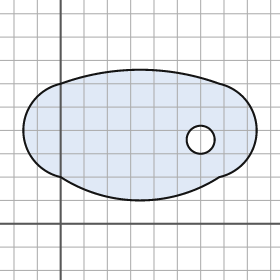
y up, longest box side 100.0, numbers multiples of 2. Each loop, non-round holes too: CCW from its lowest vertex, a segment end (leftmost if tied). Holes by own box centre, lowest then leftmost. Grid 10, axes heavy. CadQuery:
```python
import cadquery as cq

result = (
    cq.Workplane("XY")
    .moveTo(0.0, 20.0)
    .threePointArc((34.0, 10.0), (68.0, 20.0))
    .threePointArc((84.0, 40.0), (68.0, 60.0))
    .threePointArc((34.0, 66.0), (0.0, 60.0))
    .threePointArc((-16.0, 40.0), (0.0, 20.0))
    .close()
    .moveTo(60.0, 36.0)
    .circle(6.0)
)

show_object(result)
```